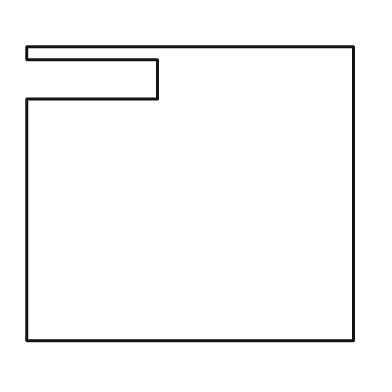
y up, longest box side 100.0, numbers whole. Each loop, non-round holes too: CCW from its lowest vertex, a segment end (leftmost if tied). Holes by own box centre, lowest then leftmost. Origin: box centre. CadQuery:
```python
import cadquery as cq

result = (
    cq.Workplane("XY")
    .moveTo(-50.0, -45.0)
    .lineTo(50.0, -45.0)
    .lineTo(50.0, 45.0)
    .lineTo(-50.0, 45.0)
    .lineTo(-50.0, 41.0)
    .lineTo(-10.0, 41.0)
    .lineTo(-10.0, 29.0)
    .lineTo(-50.0, 29.0)
    .close()
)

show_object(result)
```